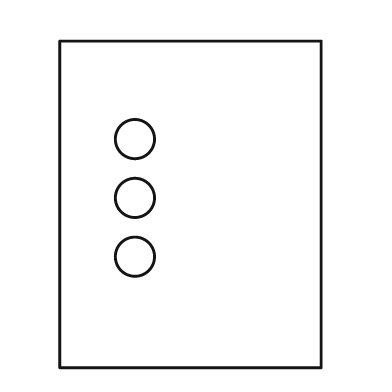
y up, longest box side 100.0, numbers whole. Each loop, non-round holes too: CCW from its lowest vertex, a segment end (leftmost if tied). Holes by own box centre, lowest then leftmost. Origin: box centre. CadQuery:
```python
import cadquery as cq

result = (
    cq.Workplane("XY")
    .moveTo(-40.0, -50.0)
    .lineTo(40.0, -50.0)
    .lineTo(40.0, 50.0)
    .lineTo(-40.0, 50.0)
    .close()
    .moveTo(-17.0, -16.0)
    .circle(6.0)
    .moveTo(-17.0, 2.0)
    .circle(6.0)
    .moveTo(-17.0, 20.0)
    .circle(6.0)
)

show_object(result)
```